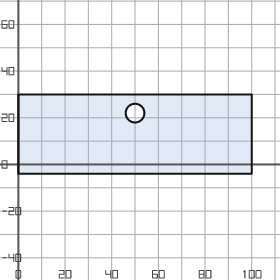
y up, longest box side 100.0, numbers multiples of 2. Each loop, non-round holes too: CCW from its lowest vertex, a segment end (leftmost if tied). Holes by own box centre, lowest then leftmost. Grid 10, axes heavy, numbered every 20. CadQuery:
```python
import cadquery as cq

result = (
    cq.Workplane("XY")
    .moveTo(0.0, -4.0)
    .lineTo(100.0, -4.0)
    .lineTo(100.0, 30.0)
    .lineTo(0.0, 30.0)
    .close()
    .moveTo(50.0, 22.0)
    .circle(4.0)
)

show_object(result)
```